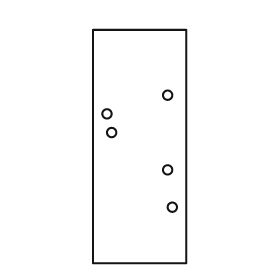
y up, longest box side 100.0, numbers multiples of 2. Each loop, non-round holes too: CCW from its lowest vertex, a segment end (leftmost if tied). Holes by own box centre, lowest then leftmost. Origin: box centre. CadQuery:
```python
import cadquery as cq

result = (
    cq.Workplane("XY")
    .moveTo(-20.0, -50.0)
    .lineTo(20.0, -50.0)
    .lineTo(20.0, 50.0)
    .lineTo(-20.0, 50.0)
    .close()
    .moveTo(14.0, -26.0)
    .circle(2.0)
    .moveTo(12.0, -10.0)
    .circle(2.0)
    .moveTo(-12.0, 6.0)
    .circle(2.0)
    .moveTo(-14.0, 14.0)
    .circle(2.0)
    .moveTo(12.0, 22.0)
    .circle(2.0)
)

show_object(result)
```